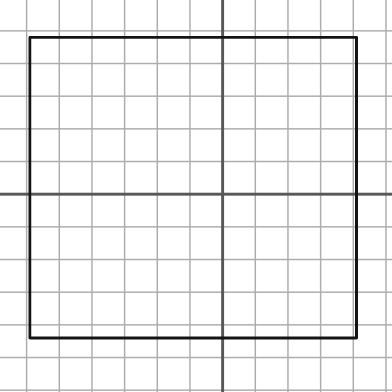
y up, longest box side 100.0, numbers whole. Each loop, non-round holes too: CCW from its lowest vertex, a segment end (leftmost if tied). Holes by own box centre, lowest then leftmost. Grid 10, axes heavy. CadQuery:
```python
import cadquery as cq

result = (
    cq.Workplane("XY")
    .moveTo(-59.0, -44.0)
    .lineTo(41.0, -44.0)
    .lineTo(41.0, 48.0)
    .lineTo(-59.0, 48.0)
    .close()
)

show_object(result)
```